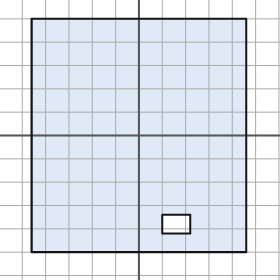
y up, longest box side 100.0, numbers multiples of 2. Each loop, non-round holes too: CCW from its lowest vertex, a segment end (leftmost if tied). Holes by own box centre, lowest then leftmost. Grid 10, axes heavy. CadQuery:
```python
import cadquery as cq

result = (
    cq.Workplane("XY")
    .moveTo(-46.0, -50.0)
    .lineTo(46.0, -50.0)
    .lineTo(46.0, 50.0)
    .lineTo(-46.0, 50.0)
    .close()
    .moveTo(10.0, -42.0)
    .lineTo(22.0, -42.0)
    .lineTo(22.0, -34.0)
    .lineTo(10.0, -34.0)
    .close()
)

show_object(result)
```